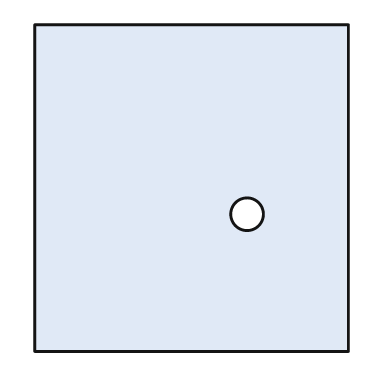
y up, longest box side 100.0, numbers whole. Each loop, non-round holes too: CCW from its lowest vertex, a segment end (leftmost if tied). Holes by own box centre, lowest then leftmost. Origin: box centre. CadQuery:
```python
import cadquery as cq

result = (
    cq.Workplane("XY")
    .moveTo(-48.0, -50.0)
    .lineTo(48.0, -50.0)
    .lineTo(48.0, 50.0)
    .lineTo(-48.0, 50.0)
    .close()
    .moveTo(17.0, -8.0)
    .circle(5.0)
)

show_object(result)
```